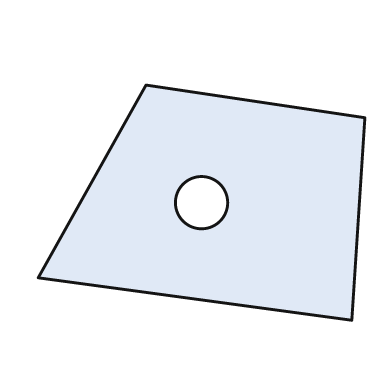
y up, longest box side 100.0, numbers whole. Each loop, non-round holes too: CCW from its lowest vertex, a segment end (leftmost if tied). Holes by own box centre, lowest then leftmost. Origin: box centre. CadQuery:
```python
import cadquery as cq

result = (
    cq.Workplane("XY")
    .moveTo(46.0, -36.0)
    .lineTo(50.0, 26.0)
    .lineTo(-17.0, 36.0)
    .lineTo(-50.0, -23.0)
    .close()
    .moveTo(0.0, 0.0)
    .circle(8.0)
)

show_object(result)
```